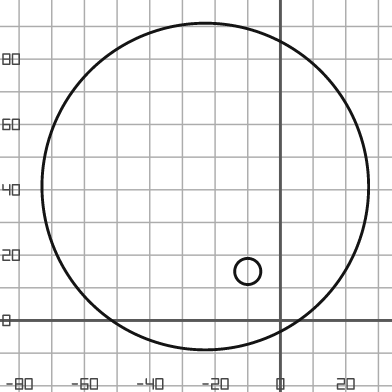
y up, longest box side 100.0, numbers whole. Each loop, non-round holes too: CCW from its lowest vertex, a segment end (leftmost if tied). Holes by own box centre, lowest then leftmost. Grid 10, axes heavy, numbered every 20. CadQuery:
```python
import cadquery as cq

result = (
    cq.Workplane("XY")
    .moveTo(-23.0, 41.0)
    .circle(50.0)
    .moveTo(-10.0, 15.0)
    .circle(4.0)
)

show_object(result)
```